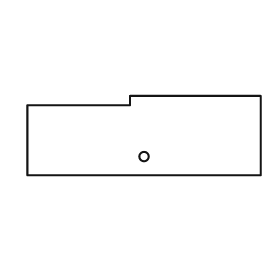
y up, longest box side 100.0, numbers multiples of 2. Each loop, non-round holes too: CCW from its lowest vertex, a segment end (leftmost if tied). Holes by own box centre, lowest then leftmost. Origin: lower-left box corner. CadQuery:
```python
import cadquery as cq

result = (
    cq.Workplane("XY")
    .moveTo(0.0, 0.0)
    .lineTo(100.0, 0.0)
    .lineTo(100.0, 34.0)
    .lineTo(44.0, 34.0)
    .lineTo(44.0, 30.0)
    .lineTo(0.0, 30.0)
    .close()
    .moveTo(50.0, 8.0)
    .circle(2.0)
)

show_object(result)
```